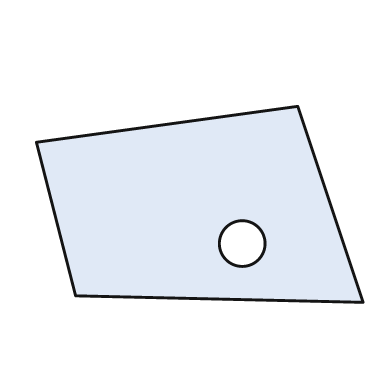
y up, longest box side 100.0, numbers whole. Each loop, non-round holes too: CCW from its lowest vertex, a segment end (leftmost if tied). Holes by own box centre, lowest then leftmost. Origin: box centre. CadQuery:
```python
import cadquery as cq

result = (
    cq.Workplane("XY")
    .moveTo(50.0, -30.0)
    .lineTo(30.0, 30.0)
    .lineTo(-50.0, 19.0)
    .lineTo(-38.0, -28.0)
    .close()
    .moveTo(13.0, -12.0)
    .circle(7.0)
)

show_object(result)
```